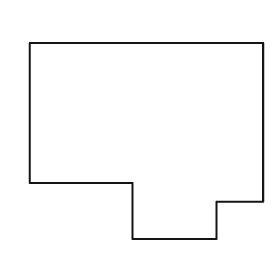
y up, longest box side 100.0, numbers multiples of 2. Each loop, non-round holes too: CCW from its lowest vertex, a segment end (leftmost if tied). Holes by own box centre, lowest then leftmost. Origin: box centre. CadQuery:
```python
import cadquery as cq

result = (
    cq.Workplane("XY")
    .moveTo(-6.0, -42.0)
    .lineTo(30.0, -42.0)
    .lineTo(30.0, -26.0)
    .lineTo(50.0, -26.0)
    .lineTo(50.0, 42.0)
    .lineTo(-50.0, 42.0)
    .lineTo(-50.0, -18.0)
    .lineTo(-6.0, -18.0)
    .close()
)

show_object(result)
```